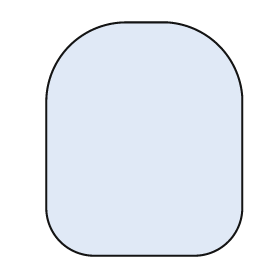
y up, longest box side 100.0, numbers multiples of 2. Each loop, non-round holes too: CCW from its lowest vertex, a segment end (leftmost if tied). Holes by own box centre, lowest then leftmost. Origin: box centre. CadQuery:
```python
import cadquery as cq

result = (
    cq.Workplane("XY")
    .moveTo(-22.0, -50.0)
    .lineTo(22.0, -50.0)
    .threePointArc((36.0, -44.0), (42.0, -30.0))
    .lineTo(42.0, 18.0)
    .threePointArc((32.0, 40.0), (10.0, 50.0))
    .lineTo(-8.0, 50.0)
    .threePointArc((-32.0, 40.0), (-42.0, 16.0))
    .lineTo(-42.0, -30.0)
    .threePointArc((-36.0, -44.0), (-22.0, -50.0))
    .close()
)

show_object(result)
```